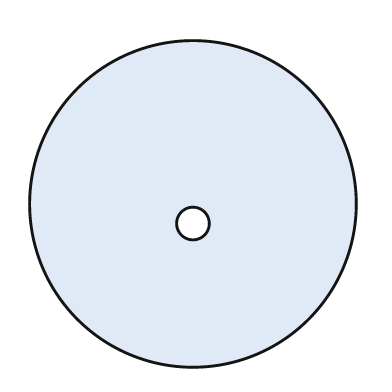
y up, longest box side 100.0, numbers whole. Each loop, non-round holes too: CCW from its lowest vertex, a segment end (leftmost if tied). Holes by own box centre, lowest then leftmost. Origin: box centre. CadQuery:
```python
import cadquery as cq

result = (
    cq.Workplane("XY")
    .moveTo(0.0, 0.0)
    .circle(50.0)
    .moveTo(0.0, -6.0)
    .circle(5.0)
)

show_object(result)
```